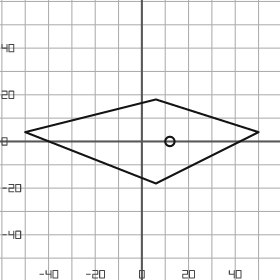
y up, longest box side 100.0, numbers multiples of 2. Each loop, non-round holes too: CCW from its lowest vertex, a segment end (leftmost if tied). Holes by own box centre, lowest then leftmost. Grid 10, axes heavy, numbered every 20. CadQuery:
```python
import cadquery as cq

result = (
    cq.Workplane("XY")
    .moveTo(6.0, -18.0)
    .lineTo(50.0, 4.0)
    .lineTo(6.0, 18.0)
    .lineTo(-50.0, 4.0)
    .close()
    .moveTo(12.0, 0.0)
    .circle(2.0)
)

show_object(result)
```